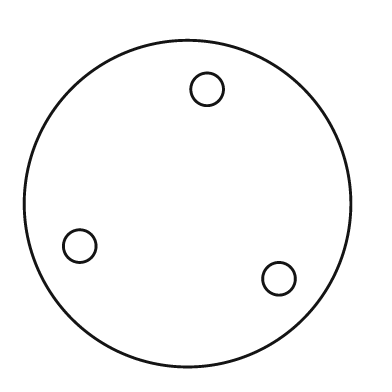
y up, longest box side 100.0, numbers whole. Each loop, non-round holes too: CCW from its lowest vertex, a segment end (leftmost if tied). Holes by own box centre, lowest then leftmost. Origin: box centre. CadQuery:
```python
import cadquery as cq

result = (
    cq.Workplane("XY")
    .moveTo(0.0, 0.0)
    .circle(50.0)
    .moveTo(28.0, -23.0)
    .circle(5.0)
    .moveTo(-33.0, -13.0)
    .circle(5.0)
    .moveTo(6.0, 35.0)
    .circle(5.0)
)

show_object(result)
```